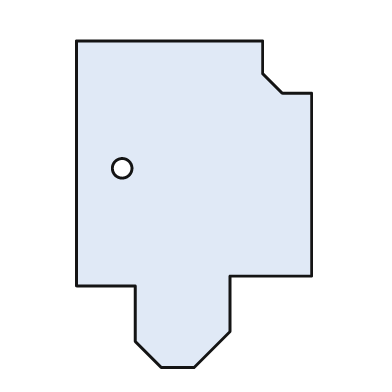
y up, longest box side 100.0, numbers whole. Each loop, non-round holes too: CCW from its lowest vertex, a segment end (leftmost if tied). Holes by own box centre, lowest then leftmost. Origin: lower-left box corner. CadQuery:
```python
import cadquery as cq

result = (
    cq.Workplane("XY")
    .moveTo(26.0, 0.0)
    .lineTo(36.0, 0.0)
    .lineTo(47.0, 11.0)
    .lineTo(47.0, 28.0)
    .lineTo(72.0, 28.0)
    .lineTo(72.0, 84.0)
    .lineTo(63.0, 84.0)
    .lineTo(57.0, 90.0)
    .lineTo(57.0, 100.0)
    .lineTo(0.0, 100.0)
    .lineTo(0.0, 25.0)
    .lineTo(18.0, 25.0)
    .lineTo(18.0, 8.0)
    .close()
    .moveTo(14.0, 61.0)
    .circle(3.0)
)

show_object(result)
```